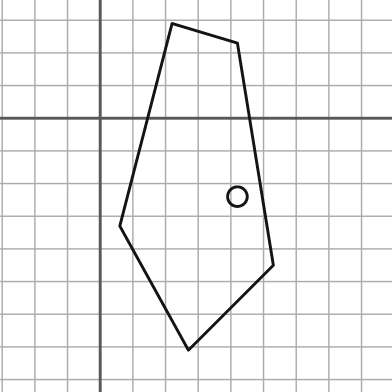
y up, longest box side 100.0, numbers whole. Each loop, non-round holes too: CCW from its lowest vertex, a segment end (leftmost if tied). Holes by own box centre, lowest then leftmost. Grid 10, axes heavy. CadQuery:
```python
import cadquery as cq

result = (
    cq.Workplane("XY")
    .moveTo(27.0, -71.0)
    .lineTo(53.0, -45.0)
    .lineTo(42.0, 23.0)
    .lineTo(22.0, 29.0)
    .lineTo(6.0, -33.0)
    .close()
    .moveTo(42.0, -24.0)
    .circle(3.0)
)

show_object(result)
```